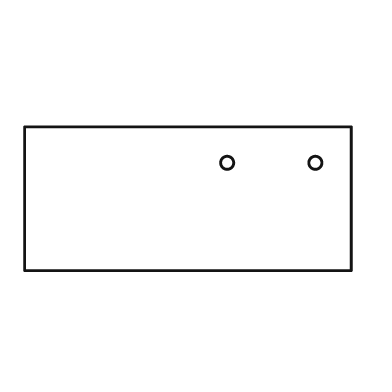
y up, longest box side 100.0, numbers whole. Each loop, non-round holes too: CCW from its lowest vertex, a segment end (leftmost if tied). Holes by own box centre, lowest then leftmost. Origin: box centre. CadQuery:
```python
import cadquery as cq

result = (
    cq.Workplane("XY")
    .moveTo(-50.0, -22.0)
    .lineTo(50.0, -22.0)
    .lineTo(50.0, 22.0)
    .lineTo(-50.0, 22.0)
    .close()
    .moveTo(12.0, 11.0)
    .circle(2.0)
    .moveTo(39.0, 11.0)
    .circle(2.0)
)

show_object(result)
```